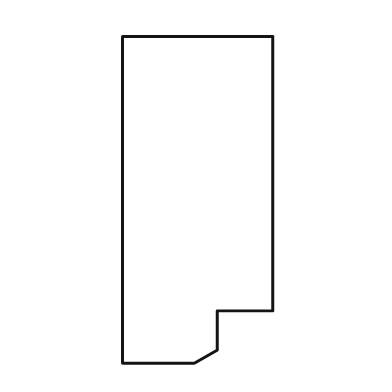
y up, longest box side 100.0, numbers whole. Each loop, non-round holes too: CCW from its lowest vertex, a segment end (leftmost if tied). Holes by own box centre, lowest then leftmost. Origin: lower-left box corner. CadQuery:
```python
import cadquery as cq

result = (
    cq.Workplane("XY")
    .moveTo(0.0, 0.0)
    .lineTo(22.0, 0.0)
    .lineTo(29.0, 4.0)
    .lineTo(29.0, 16.0)
    .lineTo(46.0, 16.0)
    .lineTo(46.0, 100.0)
    .lineTo(0.0, 100.0)
    .close()
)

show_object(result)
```